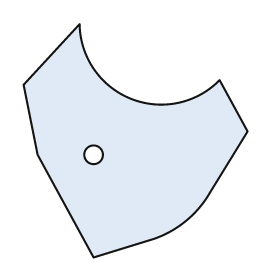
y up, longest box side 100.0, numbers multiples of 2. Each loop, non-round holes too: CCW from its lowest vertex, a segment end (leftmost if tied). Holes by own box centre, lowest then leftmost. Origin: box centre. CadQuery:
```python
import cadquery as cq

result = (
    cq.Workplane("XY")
    .moveTo(-18.0, -50.0)
    .lineTo(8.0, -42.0)
    .threePointArc((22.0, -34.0), (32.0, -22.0))
    .lineTo(48.0, 4.0)
    .lineTo(36.0, 26.0)
    .threePointArc((-2.0, 18.0), (-24.0, 50.0))
    .lineTo(-48.0, 24.0)
    .lineTo(-42.0, -6.0)
    .close()
    .moveTo(-18.0, -6.0)
    .circle(4.0)
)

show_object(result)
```